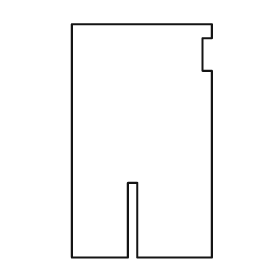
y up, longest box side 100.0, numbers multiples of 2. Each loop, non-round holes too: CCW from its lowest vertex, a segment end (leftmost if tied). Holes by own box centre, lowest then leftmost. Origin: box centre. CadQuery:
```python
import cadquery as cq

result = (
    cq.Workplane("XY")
    .moveTo(-30.0, -50.0)
    .lineTo(-6.0, -50.0)
    .lineTo(-6.0, -18.0)
    .lineTo(-2.0, -18.0)
    .lineTo(-2.0, -50.0)
    .lineTo(30.0, -50.0)
    .lineTo(30.0, 30.0)
    .lineTo(26.0, 30.0)
    .lineTo(26.0, 44.0)
    .lineTo(30.0, 44.0)
    .lineTo(30.0, 50.0)
    .lineTo(-30.0, 50.0)
    .close()
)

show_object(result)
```